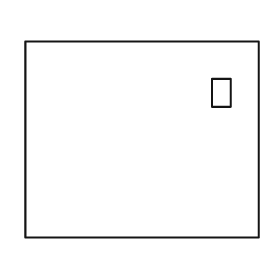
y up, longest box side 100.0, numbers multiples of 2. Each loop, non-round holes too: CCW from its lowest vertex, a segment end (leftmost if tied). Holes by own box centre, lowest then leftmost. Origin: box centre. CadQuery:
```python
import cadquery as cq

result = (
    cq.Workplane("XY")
    .moveTo(-50.0, -42.0)
    .lineTo(50.0, -42.0)
    .lineTo(50.0, 42.0)
    .lineTo(-50.0, 42.0)
    .close()
    .moveTo(30.0, 14.0)
    .lineTo(38.0, 14.0)
    .lineTo(38.0, 26.0)
    .lineTo(30.0, 26.0)
    .close()
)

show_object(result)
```